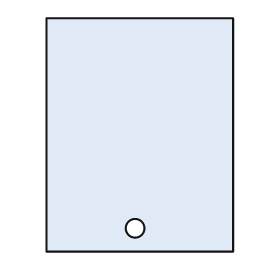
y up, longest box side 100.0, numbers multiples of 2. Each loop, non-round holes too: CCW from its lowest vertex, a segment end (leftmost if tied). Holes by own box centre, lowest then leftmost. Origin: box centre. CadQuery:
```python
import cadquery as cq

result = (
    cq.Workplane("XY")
    .moveTo(-40.0, -50.0)
    .lineTo(40.0, -50.0)
    .lineTo(40.0, 50.0)
    .lineTo(-40.0, 50.0)
    .close()
    .moveTo(-2.0, -40.0)
    .circle(4.0)
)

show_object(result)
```